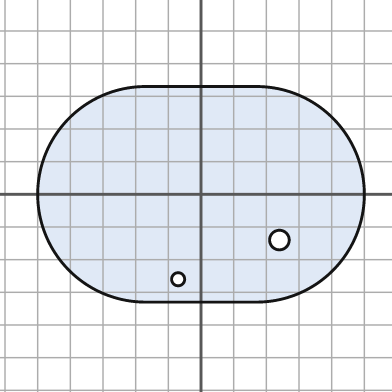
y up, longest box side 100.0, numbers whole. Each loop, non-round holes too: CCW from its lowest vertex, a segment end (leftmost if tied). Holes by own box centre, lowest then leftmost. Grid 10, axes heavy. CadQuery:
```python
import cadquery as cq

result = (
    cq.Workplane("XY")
    .moveTo(-17.0, -33.0)
    .lineTo(17.0, -33.0)
    .threePointArc((50.0, 0.0), (17.0, 33.0))
    .lineTo(-17.0, 33.0)
    .threePointArc((-50.0, 0.0), (-17.0, -33.0))
    .close()
    .moveTo(-7.0, -26.0)
    .circle(2.0)
    .moveTo(24.0, -14.0)
    .circle(3.0)
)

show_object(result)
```